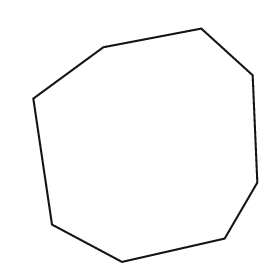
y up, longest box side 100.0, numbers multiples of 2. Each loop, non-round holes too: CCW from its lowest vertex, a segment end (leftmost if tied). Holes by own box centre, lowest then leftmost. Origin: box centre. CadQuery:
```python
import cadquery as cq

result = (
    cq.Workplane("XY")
    .moveTo(-10.0, -50.0)
    .lineTo(34.0, -40.0)
    .lineTo(48.0, -16.0)
    .lineTo(46.0, 30.0)
    .lineTo(24.0, 50.0)
    .lineTo(-18.0, 42.0)
    .lineTo(-48.0, 20.0)
    .lineTo(-40.0, -34.0)
    .close()
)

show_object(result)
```